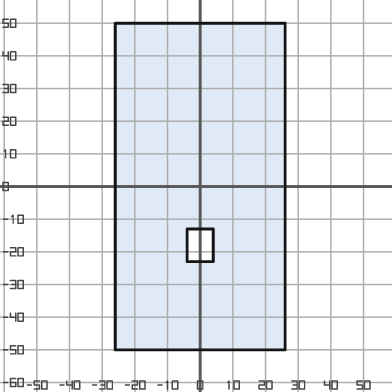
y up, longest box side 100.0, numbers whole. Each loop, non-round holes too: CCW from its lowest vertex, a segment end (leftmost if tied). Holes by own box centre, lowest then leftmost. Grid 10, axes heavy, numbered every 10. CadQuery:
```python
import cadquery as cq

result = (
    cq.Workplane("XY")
    .moveTo(-26.0, -50.0)
    .lineTo(26.0, -50.0)
    .lineTo(26.0, 50.0)
    .lineTo(-26.0, 50.0)
    .close()
    .moveTo(-4.0, -23.0)
    .lineTo(4.0, -23.0)
    .lineTo(4.0, -13.0)
    .lineTo(-4.0, -13.0)
    .close()
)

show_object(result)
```